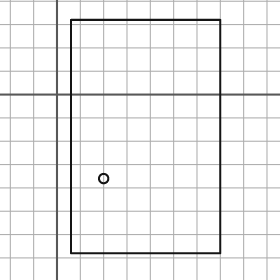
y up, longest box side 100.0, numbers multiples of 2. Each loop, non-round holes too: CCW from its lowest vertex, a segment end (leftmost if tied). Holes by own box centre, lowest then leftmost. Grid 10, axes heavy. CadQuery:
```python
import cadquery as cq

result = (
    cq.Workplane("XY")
    .moveTo(6.0, -68.0)
    .lineTo(70.0, -68.0)
    .lineTo(70.0, 32.0)
    .lineTo(6.0, 32.0)
    .close()
    .moveTo(20.0, -36.0)
    .circle(2.0)
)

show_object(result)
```